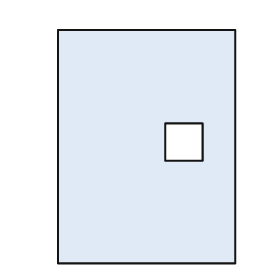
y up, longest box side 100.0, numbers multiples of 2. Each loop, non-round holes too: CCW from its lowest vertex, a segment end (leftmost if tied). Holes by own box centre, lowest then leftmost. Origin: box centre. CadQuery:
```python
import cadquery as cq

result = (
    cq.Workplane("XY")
    .moveTo(-38.0, -50.0)
    .lineTo(38.0, -50.0)
    .lineTo(38.0, 50.0)
    .lineTo(-38.0, 50.0)
    .close()
    .moveTo(8.0, -6.0)
    .lineTo(24.0, -6.0)
    .lineTo(24.0, 10.0)
    .lineTo(8.0, 10.0)
    .close()
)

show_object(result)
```